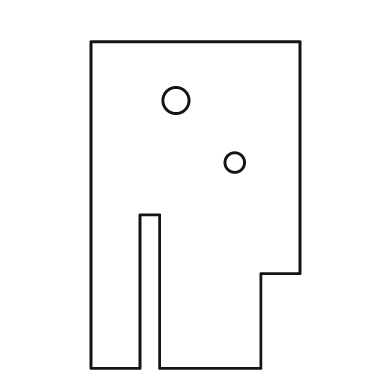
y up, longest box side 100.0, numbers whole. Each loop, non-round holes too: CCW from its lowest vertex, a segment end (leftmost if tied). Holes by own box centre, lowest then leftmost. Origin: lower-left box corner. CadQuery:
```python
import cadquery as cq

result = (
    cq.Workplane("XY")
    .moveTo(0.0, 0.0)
    .lineTo(15.0, 0.0)
    .lineTo(15.0, 47.0)
    .lineTo(21.0, 47.0)
    .lineTo(21.0, 0.0)
    .lineTo(52.0, 0.0)
    .lineTo(52.0, 29.0)
    .lineTo(64.0, 29.0)
    .lineTo(64.0, 100.0)
    .lineTo(0.0, 100.0)
    .close()
    .moveTo(44.0, 63.0)
    .circle(3.0)
    .moveTo(26.0, 82.0)
    .circle(4.0)
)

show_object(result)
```